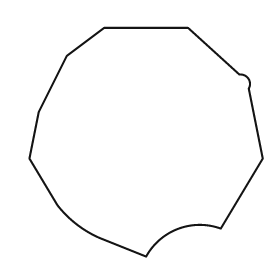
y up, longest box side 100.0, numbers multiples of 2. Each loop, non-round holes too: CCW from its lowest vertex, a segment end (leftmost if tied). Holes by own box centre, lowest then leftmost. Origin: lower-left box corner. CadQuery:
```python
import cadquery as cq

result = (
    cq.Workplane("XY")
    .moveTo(50.0, 0.0)
    .threePointArc((64.0, 12.0), (82.0, 12.0))
    .lineTo(100.0, 42.0)
    .lineTo(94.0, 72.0)
    .threePointArc((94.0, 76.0), (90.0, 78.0))
    .lineTo(68.0, 98.0)
    .lineTo(32.0, 98.0)
    .lineTo(16.0, 86.0)
    .lineTo(4.0, 62.0)
    .lineTo(0.0, 42.0)
    .lineTo(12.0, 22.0)
    .threePointArc((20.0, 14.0), (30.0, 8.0))
    .close()
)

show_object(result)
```